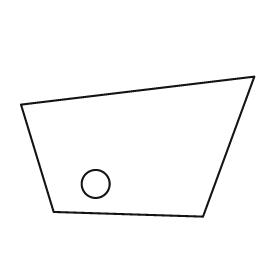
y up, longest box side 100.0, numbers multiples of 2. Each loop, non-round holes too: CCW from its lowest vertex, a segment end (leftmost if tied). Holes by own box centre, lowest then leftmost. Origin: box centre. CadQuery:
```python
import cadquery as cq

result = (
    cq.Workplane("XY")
    .moveTo(28.0, -30.0)
    .lineTo(50.0, 30.0)
    .lineTo(-50.0, 18.0)
    .lineTo(-36.0, -28.0)
    .close()
    .moveTo(-18.0, -16.0)
    .circle(6.0)
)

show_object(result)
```